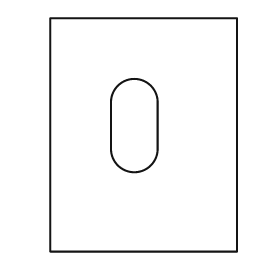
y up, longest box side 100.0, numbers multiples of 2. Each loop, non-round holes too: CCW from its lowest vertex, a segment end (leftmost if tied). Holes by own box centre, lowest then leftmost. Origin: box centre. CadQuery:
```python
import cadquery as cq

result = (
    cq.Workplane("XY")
    .moveTo(-40.0, -50.0)
    .lineTo(40.0, -50.0)
    .lineTo(40.0, 50.0)
    .lineTo(-40.0, 50.0)
    .close()
    .moveTo(-14.0, -6.0)
    .threePointArc((-4.0, -16.0), (6.0, -6.0))
    .lineTo(6.0, 14.0)
    .threePointArc((-4.0, 24.0), (-14.0, 14.0))
    .close()
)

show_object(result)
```